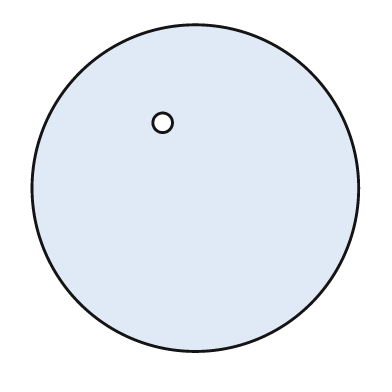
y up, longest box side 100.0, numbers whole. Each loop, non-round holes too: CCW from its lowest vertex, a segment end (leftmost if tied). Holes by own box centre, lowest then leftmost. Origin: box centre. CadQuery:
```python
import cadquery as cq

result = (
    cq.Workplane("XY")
    .moveTo(0.0, 0.0)
    .circle(50.0)
    .moveTo(-10.0, 20.0)
    .circle(3.0)
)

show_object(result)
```